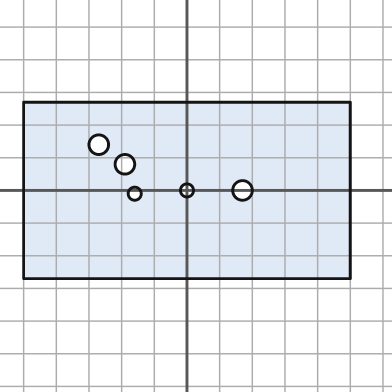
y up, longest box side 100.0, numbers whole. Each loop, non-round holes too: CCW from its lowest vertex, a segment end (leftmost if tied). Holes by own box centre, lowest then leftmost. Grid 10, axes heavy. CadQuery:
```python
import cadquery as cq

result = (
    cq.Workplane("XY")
    .moveTo(-50.0, -27.0)
    .lineTo(50.0, -27.0)
    .lineTo(50.0, 27.0)
    .lineTo(-50.0, 27.0)
    .close()
    .moveTo(-16.0, -1.0)
    .circle(2.0)
    .moveTo(0.0, 0.0)
    .circle(2.0)
    .moveTo(17.0, 0.0)
    .circle(3.0)
    .moveTo(-19.0, 8.0)
    .circle(3.0)
    .moveTo(-27.0, 14.0)
    .circle(3.0)
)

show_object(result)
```